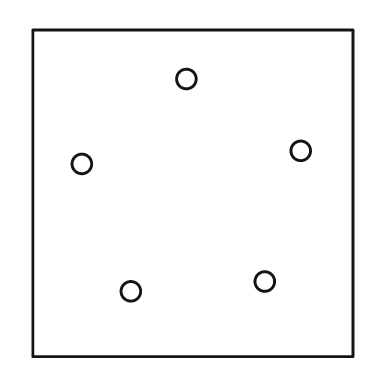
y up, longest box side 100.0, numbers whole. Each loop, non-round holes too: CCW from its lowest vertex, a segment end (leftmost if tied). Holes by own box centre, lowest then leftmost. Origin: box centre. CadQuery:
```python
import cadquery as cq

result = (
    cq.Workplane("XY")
    .moveTo(-49.0, -50.0)
    .lineTo(49.0, -50.0)
    .lineTo(49.0, 50.0)
    .lineTo(-49.0, 50.0)
    .close()
    .moveTo(-19.0, -30.0)
    .circle(3.0)
    .moveTo(22.0, -27.0)
    .circle(3.0)
    .moveTo(-34.0, 9.0)
    .circle(3.0)
    .moveTo(33.0, 13.0)
    .circle(3.0)
    .moveTo(-2.0, 35.0)
    .circle(3.0)
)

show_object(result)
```